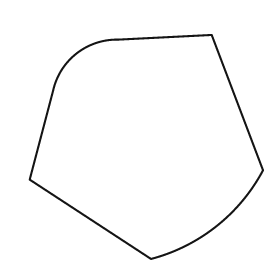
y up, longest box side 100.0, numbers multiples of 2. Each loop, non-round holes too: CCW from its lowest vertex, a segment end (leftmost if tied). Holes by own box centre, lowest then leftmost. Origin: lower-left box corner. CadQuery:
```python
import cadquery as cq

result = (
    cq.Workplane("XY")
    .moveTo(52.0, 0.0)
    .threePointArc((80.0, 14.0), (100.0, 38.0))
    .lineTo(78.0, 96.0)
    .lineTo(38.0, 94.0)
    .threePointArc((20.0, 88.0), (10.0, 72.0))
    .lineTo(0.0, 34.0)
    .close()
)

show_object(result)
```